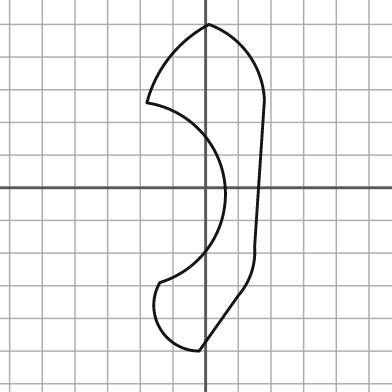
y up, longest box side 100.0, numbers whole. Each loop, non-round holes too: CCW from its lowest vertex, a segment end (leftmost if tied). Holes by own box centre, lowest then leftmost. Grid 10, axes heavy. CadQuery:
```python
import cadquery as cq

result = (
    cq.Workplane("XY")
    .moveTo(-2.0, -50.0)
    .lineTo(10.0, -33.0)
    .threePointArc((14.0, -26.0), (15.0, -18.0))
    .lineTo(18.0, 27.0)
    .threePointArc((13.0, 41.0), (1.0, 50.0))
    .threePointArc((-11.0, 40.0), (-18.0, 26.0))
    .threePointArc((6.0, 0.0), (-14.0, -29.0))
    .threePointArc((-14.0, -43.0), (-2.0, -50.0))
    .close()
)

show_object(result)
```